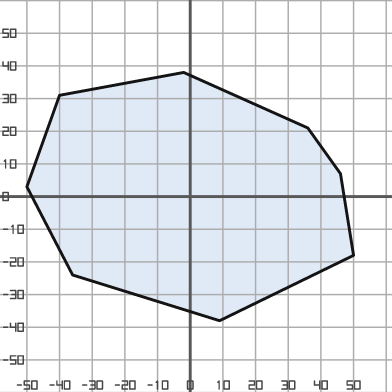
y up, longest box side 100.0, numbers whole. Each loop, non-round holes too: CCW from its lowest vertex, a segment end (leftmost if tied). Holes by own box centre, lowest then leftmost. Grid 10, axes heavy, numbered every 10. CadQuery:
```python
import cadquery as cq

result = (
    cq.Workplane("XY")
    .moveTo(9.0, -38.0)
    .lineTo(50.0, -18.0)
    .lineTo(46.0, 7.0)
    .lineTo(36.0, 21.0)
    .lineTo(-2.0, 38.0)
    .lineTo(-40.0, 31.0)
    .lineTo(-50.0, 3.0)
    .lineTo(-36.0, -24.0)
    .close()
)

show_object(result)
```